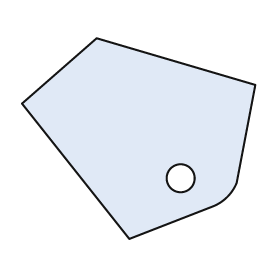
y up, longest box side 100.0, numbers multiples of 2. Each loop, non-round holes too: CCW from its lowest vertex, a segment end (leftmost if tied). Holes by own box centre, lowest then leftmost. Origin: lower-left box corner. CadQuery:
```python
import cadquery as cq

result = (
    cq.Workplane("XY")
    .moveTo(46.0, 0.0)
    .lineTo(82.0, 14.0)
    .threePointArc((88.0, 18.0), (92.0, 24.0))
    .lineTo(100.0, 66.0)
    .lineTo(32.0, 86.0)
    .lineTo(0.0, 58.0)
    .close()
    .moveTo(68.0, 26.0)
    .circle(6.0)
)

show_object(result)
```